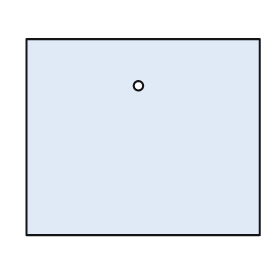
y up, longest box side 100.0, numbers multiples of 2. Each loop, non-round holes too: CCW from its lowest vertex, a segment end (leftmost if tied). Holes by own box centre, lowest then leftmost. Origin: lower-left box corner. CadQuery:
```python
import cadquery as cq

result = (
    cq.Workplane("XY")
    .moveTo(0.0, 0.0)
    .lineTo(100.0, 0.0)
    .lineTo(100.0, 84.0)
    .lineTo(0.0, 84.0)
    .close()
    .moveTo(48.0, 64.0)
    .circle(2.0)
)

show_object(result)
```